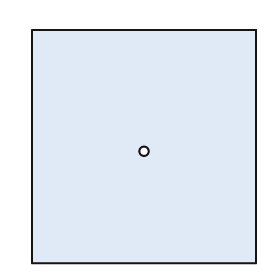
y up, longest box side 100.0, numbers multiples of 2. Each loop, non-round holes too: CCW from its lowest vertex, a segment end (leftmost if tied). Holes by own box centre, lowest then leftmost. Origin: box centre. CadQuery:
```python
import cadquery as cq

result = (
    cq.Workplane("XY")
    .moveTo(-48.0, -50.0)
    .lineTo(48.0, -50.0)
    .lineTo(48.0, 50.0)
    .lineTo(-48.0, 50.0)
    .close()
    .moveTo(0.0, -2.0)
    .circle(2.0)
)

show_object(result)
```